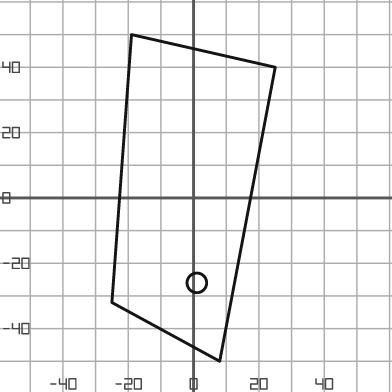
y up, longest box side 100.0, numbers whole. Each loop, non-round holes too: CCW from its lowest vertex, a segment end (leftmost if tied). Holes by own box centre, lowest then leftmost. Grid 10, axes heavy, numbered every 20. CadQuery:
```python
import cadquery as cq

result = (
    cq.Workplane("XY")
    .moveTo(8.0, -50.0)
    .lineTo(25.0, 40.0)
    .lineTo(-19.0, 50.0)
    .lineTo(-25.0, -32.0)
    .close()
    .moveTo(1.0, -26.0)
    .circle(3.0)
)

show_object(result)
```